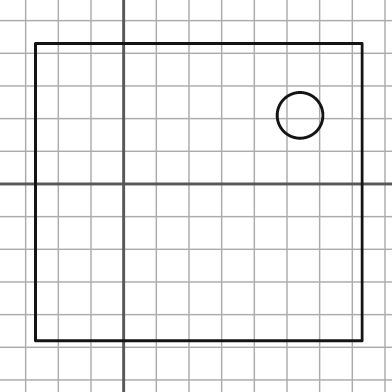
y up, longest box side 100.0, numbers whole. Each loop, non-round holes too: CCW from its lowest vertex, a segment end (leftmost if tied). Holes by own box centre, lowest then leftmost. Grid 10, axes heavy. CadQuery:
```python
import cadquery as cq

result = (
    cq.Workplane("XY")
    .moveTo(-27.0, -48.0)
    .lineTo(73.0, -48.0)
    .lineTo(73.0, 43.0)
    .lineTo(-27.0, 43.0)
    .close()
    .moveTo(54.0, 21.0)
    .circle(7.0)
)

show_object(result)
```